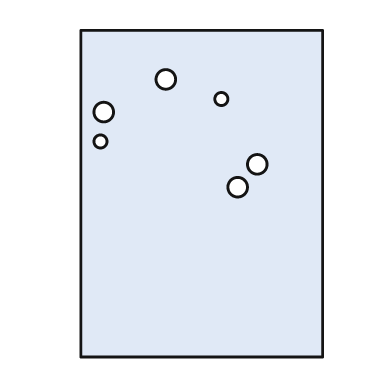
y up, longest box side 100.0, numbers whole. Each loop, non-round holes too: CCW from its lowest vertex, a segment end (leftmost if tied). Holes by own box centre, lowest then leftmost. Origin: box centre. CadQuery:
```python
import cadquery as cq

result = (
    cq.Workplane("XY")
    .moveTo(-37.0, -50.0)
    .lineTo(37.0, -50.0)
    .lineTo(37.0, 50.0)
    .lineTo(-37.0, 50.0)
    .close()
    .moveTo(11.0, 2.0)
    .circle(3.0)
    .moveTo(17.0, 9.0)
    .circle(3.0)
    .moveTo(-31.0, 16.0)
    .circle(2.0)
    .moveTo(-30.0, 25.0)
    .circle(3.0)
    .moveTo(6.0, 29.0)
    .circle(2.0)
    .moveTo(-11.0, 35.0)
    .circle(3.0)
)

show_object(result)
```